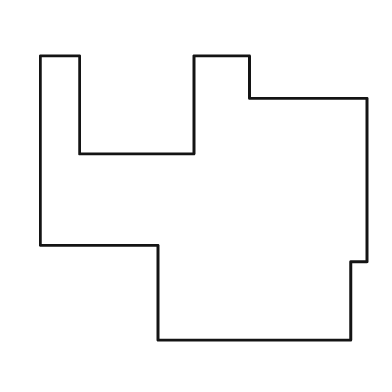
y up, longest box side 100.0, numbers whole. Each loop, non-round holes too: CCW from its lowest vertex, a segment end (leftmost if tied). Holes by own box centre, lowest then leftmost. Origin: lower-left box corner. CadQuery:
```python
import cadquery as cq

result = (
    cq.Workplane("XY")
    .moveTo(36.0, 0.0)
    .lineTo(95.0, 0.0)
    .lineTo(95.0, 24.0)
    .lineTo(100.0, 24.0)
    .lineTo(100.0, 74.0)
    .lineTo(64.0, 74.0)
    .lineTo(64.0, 87.0)
    .lineTo(47.0, 87.0)
    .lineTo(47.0, 57.0)
    .lineTo(12.0, 57.0)
    .lineTo(12.0, 87.0)
    .lineTo(0.0, 87.0)
    .lineTo(0.0, 29.0)
    .lineTo(36.0, 29.0)
    .close()
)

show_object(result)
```